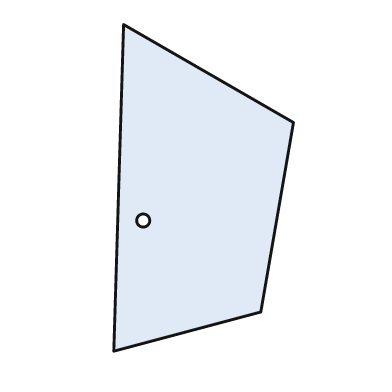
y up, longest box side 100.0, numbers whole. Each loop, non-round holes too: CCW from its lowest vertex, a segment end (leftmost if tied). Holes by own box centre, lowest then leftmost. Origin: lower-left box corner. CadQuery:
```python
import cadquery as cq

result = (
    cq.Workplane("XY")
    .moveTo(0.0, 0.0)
    .lineTo(45.0, 12.0)
    .lineTo(55.0, 70.0)
    .lineTo(3.0, 100.0)
    .close()
    .moveTo(9.0, 40.0)
    .circle(2.0)
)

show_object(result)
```